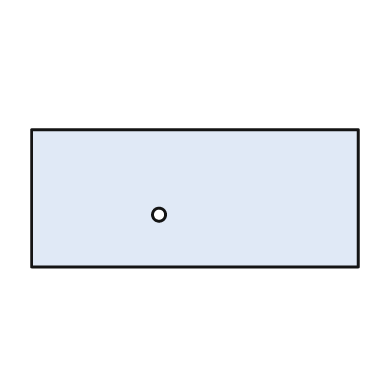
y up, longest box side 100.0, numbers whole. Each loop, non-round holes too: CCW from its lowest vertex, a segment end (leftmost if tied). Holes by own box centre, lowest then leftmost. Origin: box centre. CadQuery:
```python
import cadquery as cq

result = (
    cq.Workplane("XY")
    .moveTo(-50.0, -21.0)
    .lineTo(50.0, -21.0)
    .lineTo(50.0, 21.0)
    .lineTo(-50.0, 21.0)
    .close()
    .moveTo(-11.0, -5.0)
    .circle(2.0)
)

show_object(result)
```